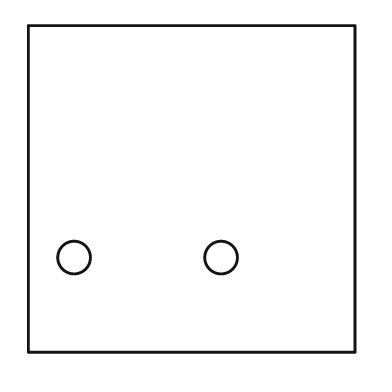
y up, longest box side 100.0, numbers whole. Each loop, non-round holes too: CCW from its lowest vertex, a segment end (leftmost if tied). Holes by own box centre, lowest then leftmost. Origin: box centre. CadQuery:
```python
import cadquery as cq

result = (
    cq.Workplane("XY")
    .moveTo(-50.0, -50.0)
    .lineTo(50.0, -50.0)
    .lineTo(50.0, 50.0)
    .lineTo(-50.0, 50.0)
    .close()
    .moveTo(-36.0, -21.0)
    .circle(5.0)
    .moveTo(9.0, -21.0)
    .circle(5.0)
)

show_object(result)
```